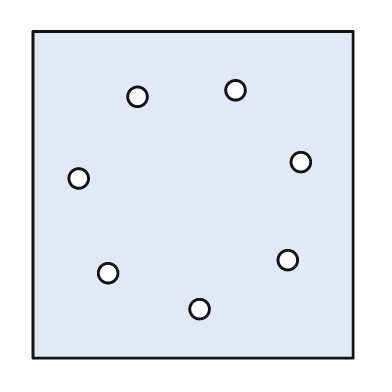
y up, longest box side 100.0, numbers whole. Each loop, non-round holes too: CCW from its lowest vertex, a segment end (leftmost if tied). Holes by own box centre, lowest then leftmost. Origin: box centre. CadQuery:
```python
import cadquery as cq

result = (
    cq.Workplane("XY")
    .moveTo(-49.0, -50.0)
    .lineTo(49.0, -50.0)
    .lineTo(49.0, 50.0)
    .lineTo(-49.0, 50.0)
    .close()
    .moveTo(2.0, -35.0)
    .circle(3.0)
    .moveTo(-26.0, -24.0)
    .circle(3.0)
    .moveTo(29.0, -20.0)
    .circle(3.0)
    .moveTo(-35.0, 5.0)
    .circle(3.0)
    .moveTo(33.0, 10.0)
    .circle(3.0)
    .moveTo(-17.0, 30.0)
    .circle(3.0)
    .moveTo(13.0, 32.0)
    .circle(3.0)
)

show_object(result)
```